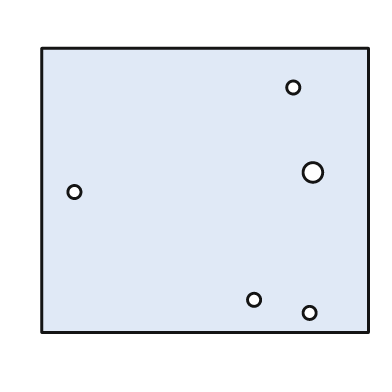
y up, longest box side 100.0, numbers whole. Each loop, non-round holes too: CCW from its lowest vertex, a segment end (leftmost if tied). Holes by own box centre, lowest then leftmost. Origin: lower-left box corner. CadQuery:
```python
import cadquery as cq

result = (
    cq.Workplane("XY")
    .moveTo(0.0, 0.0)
    .lineTo(100.0, 0.0)
    .lineTo(100.0, 87.0)
    .lineTo(0.0, 87.0)
    .close()
    .moveTo(82.0, 6.0)
    .circle(2.0)
    .moveTo(65.0, 10.0)
    .circle(2.0)
    .moveTo(10.0, 43.0)
    .circle(2.0)
    .moveTo(83.0, 49.0)
    .circle(3.0)
    .moveTo(77.0, 75.0)
    .circle(2.0)
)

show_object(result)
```